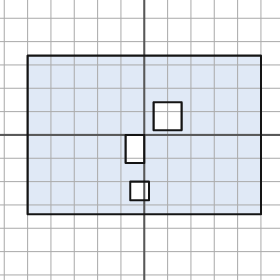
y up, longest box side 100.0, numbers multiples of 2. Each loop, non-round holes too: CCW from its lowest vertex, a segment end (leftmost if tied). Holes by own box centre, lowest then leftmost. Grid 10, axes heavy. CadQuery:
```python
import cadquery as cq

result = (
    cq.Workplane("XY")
    .moveTo(-50.0, -34.0)
    .lineTo(50.0, -34.0)
    .lineTo(50.0, 34.0)
    .lineTo(-50.0, 34.0)
    .close()
    .moveTo(-6.0, -28.0)
    .lineTo(2.0, -28.0)
    .lineTo(2.0, -20.0)
    .lineTo(-6.0, -20.0)
    .close()
    .moveTo(-8.0, -12.0)
    .lineTo(0.0, -12.0)
    .lineTo(0.0, 0.0)
    .lineTo(-8.0, 0.0)
    .close()
    .moveTo(4.0, 2.0)
    .lineTo(16.0, 2.0)
    .lineTo(16.0, 14.0)
    .lineTo(4.0, 14.0)
    .close()
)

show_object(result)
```